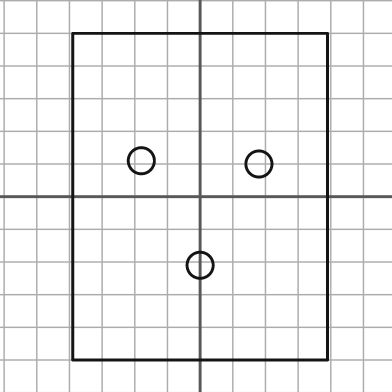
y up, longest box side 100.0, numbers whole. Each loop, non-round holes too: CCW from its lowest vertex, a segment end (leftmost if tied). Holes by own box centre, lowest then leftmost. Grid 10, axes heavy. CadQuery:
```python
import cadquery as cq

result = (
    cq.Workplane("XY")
    .moveTo(-39.0, -50.0)
    .lineTo(39.0, -50.0)
    .lineTo(39.0, 50.0)
    .lineTo(-39.0, 50.0)
    .close()
    .moveTo(0.0, -21.0)
    .circle(4.0)
    .moveTo(18.0, 10.0)
    .circle(4.0)
    .moveTo(-18.0, 11.0)
    .circle(4.0)
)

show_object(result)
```